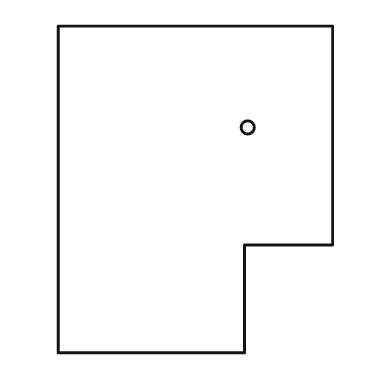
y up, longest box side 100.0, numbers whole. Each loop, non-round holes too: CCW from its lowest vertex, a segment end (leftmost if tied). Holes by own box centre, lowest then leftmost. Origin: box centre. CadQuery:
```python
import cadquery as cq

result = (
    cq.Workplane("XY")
    .moveTo(-42.0, -50.0)
    .lineTo(15.0, -50.0)
    .lineTo(15.0, -17.0)
    .lineTo(42.0, -17.0)
    .lineTo(42.0, 50.0)
    .lineTo(-42.0, 50.0)
    .close()
    .moveTo(16.0, 19.0)
    .circle(2.0)
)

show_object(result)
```